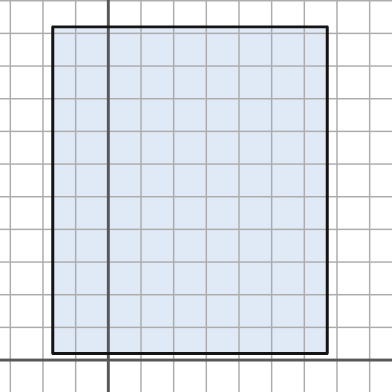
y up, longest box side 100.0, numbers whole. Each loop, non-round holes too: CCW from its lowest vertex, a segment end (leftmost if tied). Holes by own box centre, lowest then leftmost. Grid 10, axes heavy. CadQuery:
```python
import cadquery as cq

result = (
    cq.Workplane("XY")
    .moveTo(-17.0, 2.0)
    .lineTo(67.0, 2.0)
    .lineTo(67.0, 102.0)
    .lineTo(-17.0, 102.0)
    .close()
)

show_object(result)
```